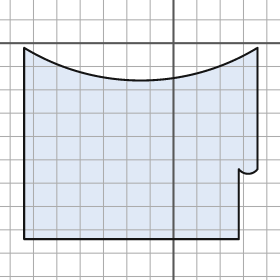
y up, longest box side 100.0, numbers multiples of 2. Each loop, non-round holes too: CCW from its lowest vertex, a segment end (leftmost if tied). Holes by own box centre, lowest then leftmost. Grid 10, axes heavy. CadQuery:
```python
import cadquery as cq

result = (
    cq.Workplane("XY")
    .moveTo(-64.0, -84.0)
    .lineTo(28.0, -84.0)
    .lineTo(28.0, -54.0)
    .threePointArc((32.0, -56.0), (36.0, -54.0))
    .lineTo(36.0, -2.0)
    .threePointArc((-14.0, -16.0), (-64.0, -2.0))
    .close()
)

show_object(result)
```